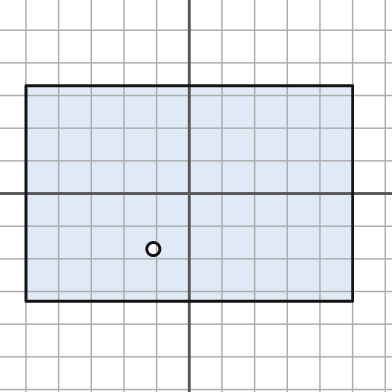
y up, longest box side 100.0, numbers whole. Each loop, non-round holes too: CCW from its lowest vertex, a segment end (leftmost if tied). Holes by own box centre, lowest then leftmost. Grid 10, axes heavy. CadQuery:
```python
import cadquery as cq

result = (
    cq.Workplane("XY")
    .moveTo(-50.0, -33.0)
    .lineTo(50.0, -33.0)
    .lineTo(50.0, 33.0)
    .lineTo(-50.0, 33.0)
    .close()
    .moveTo(-11.0, -17.0)
    .circle(2.0)
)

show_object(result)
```